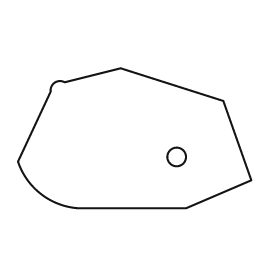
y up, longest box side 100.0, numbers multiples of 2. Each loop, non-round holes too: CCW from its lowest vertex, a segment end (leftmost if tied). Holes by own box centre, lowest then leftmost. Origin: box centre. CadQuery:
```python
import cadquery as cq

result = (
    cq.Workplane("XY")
    .moveTo(-24.0, -30.0)
    .lineTo(22.0, -30.0)
    .lineTo(50.0, -18.0)
    .lineTo(38.0, 16.0)
    .lineTo(-6.0, 30.0)
    .lineTo(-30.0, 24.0)
    .threePointArc((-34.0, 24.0), (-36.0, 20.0))
    .lineTo(-50.0, -10.0)
    .threePointArc((-40.0, -24.0), (-24.0, -30.0))
    .close()
    .moveTo(18.0, -8.0)
    .circle(4.0)
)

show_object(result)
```